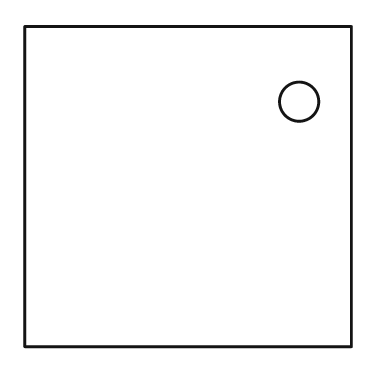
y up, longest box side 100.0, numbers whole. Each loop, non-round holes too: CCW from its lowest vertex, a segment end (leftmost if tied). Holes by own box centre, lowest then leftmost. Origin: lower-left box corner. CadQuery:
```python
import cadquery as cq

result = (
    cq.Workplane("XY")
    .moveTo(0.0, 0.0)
    .lineTo(100.0, 0.0)
    .lineTo(100.0, 98.0)
    .lineTo(0.0, 98.0)
    .close()
    .moveTo(84.0, 75.0)
    .circle(6.0)
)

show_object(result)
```